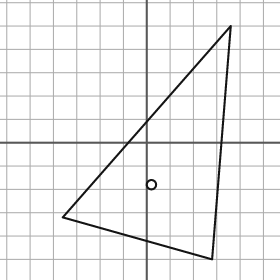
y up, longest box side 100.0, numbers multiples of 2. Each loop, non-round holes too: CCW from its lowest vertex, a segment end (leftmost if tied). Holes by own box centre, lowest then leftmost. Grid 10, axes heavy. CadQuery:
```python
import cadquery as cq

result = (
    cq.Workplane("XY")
    .moveTo(28.0, -50.0)
    .lineTo(36.0, 50.0)
    .lineTo(-36.0, -32.0)
    .close()
    .moveTo(2.0, -18.0)
    .circle(2.0)
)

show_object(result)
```